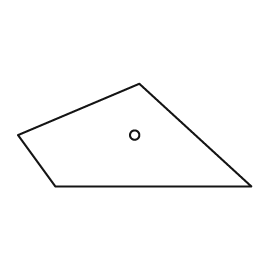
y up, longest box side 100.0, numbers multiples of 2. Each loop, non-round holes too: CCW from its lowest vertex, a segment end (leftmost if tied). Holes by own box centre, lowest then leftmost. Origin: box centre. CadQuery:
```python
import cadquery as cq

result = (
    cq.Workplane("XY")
    .moveTo(-34.0, -22.0)
    .lineTo(50.0, -22.0)
    .lineTo(2.0, 22.0)
    .lineTo(-50.0, 0.0)
    .close()
    .moveTo(0.0, 0.0)
    .circle(2.0)
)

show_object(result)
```